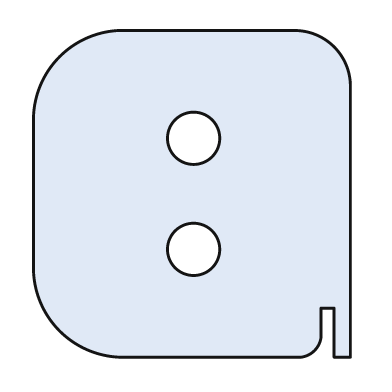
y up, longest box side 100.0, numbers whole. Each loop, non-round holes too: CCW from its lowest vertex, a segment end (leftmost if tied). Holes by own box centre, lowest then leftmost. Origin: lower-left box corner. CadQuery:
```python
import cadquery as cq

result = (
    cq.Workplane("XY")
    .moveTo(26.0, 0.0)
    .lineTo(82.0, 0.0)
    .threePointArc((86.0, 2.0), (88.0, 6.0))
    .lineTo(88.0, 15.0)
    .lineTo(92.0, 15.0)
    .lineTo(92.0, 0.0)
    .lineTo(97.0, 0.0)
    .lineTo(97.0, 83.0)
    .threePointArc((92.0, 95.0), (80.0, 100.0))
    .lineTo(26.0, 100.0)
    .threePointArc((8.0, 92.0), (0.0, 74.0))
    .lineTo(0.0, 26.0)
    .threePointArc((8.0, 8.0), (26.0, 0.0))
    .close()
    .moveTo(49.0, 33.0)
    .circle(8.0)
    .moveTo(49.0, 67.0)
    .circle(8.0)
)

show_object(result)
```